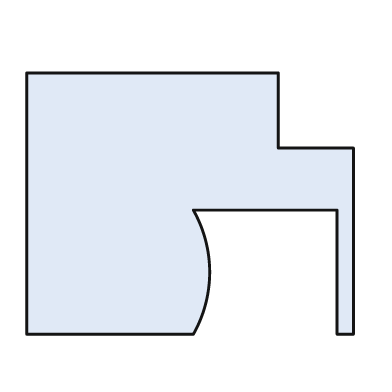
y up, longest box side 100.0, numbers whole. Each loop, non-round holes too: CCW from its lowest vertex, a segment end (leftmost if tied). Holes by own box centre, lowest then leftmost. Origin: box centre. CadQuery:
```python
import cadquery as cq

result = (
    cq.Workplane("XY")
    .moveTo(-50.0, -40.0)
    .lineTo(1.0, -40.0)
    .threePointArc((6.0, -21.0), (1.0, -2.0))
    .lineTo(45.0, -2.0)
    .lineTo(45.0, -40.0)
    .lineTo(50.0, -40.0)
    .lineTo(50.0, 17.0)
    .lineTo(27.0, 17.0)
    .lineTo(27.0, 40.0)
    .lineTo(-50.0, 40.0)
    .close()
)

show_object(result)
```